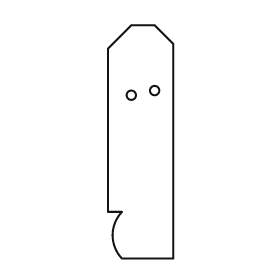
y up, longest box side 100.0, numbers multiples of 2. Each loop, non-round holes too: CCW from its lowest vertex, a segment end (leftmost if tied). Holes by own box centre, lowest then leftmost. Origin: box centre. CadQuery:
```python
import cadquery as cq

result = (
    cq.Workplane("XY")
    .moveTo(-8.0, -50.0)
    .lineTo(14.0, -50.0)
    .lineTo(14.0, 42.0)
    .lineTo(6.0, 50.0)
    .lineTo(-4.0, 50.0)
    .lineTo(-14.0, 40.0)
    .lineTo(-14.0, -30.0)
    .lineTo(-8.0, -30.0)
    .threePointArc((-12.0, -40.0), (-8.0, -50.0))
    .close()
    .moveTo(-4.0, 20.0)
    .circle(2.0)
    .moveTo(6.0, 22.0)
    .circle(2.0)
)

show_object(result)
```